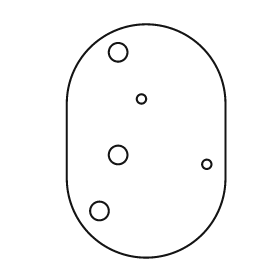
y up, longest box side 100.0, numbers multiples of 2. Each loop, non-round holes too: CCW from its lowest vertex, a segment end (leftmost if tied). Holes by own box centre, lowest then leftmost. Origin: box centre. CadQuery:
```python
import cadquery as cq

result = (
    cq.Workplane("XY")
    .moveTo(-34.0, -16.0)
    .threePointArc((0.0, -50.0), (34.0, -16.0))
    .lineTo(34.0, 16.0)
    .threePointArc((0.0, 50.0), (-34.0, 16.0))
    .close()
    .moveTo(-20.0, -30.0)
    .circle(4.0)
    .moveTo(26.0, -10.0)
    .circle(2.0)
    .moveTo(-12.0, -6.0)
    .circle(4.0)
    .moveTo(-2.0, 18.0)
    .circle(2.0)
    .moveTo(-12.0, 38.0)
    .circle(4.0)
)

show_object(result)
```